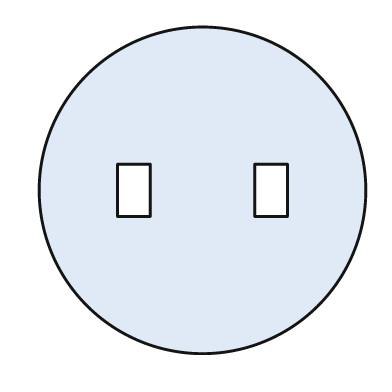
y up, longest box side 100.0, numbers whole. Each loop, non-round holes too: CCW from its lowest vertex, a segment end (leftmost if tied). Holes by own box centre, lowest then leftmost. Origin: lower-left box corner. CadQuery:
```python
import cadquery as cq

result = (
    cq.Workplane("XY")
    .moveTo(50.0, 50.0)
    .circle(50.0)
    .moveTo(24.0, 42.0)
    .lineTo(34.0, 42.0)
    .lineTo(34.0, 58.0)
    .lineTo(24.0, 58.0)
    .close()
    .moveTo(66.0, 42.0)
    .lineTo(76.0, 42.0)
    .lineTo(76.0, 58.0)
    .lineTo(66.0, 58.0)
    .close()
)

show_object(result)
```